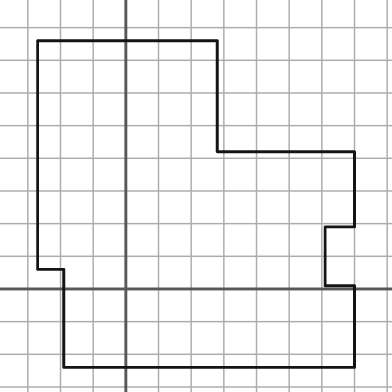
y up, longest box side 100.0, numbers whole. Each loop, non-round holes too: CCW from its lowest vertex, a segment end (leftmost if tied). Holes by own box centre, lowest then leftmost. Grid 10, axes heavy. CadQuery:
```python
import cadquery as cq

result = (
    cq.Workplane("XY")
    .moveTo(-19.0, -24.0)
    .lineTo(70.0, -24.0)
    .lineTo(70.0, 1.0)
    .lineTo(61.0, 1.0)
    .lineTo(61.0, 19.0)
    .lineTo(70.0, 19.0)
    .lineTo(70.0, 42.0)
    .lineTo(28.0, 42.0)
    .lineTo(28.0, 76.0)
    .lineTo(-27.0, 76.0)
    .lineTo(-27.0, 6.0)
    .lineTo(-19.0, 6.0)
    .close()
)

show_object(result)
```